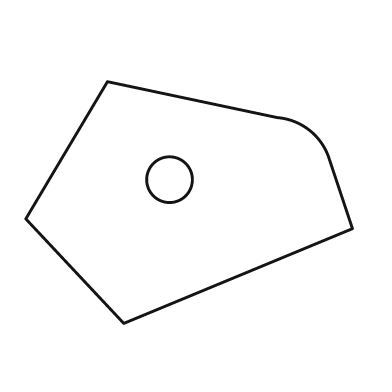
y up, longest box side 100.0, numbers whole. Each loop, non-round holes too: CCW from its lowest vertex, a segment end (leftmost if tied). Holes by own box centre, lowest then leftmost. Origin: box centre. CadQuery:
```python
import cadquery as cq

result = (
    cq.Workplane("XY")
    .moveTo(-20.0, -37.0)
    .lineTo(50.0, -8.0)
    .lineTo(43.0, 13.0)
    .threePointArc((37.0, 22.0), (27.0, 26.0))
    .lineTo(-25.0, 37.0)
    .lineTo(-50.0, -5.0)
    .close()
    .moveTo(-6.0, 7.0)
    .circle(7.0)
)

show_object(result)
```